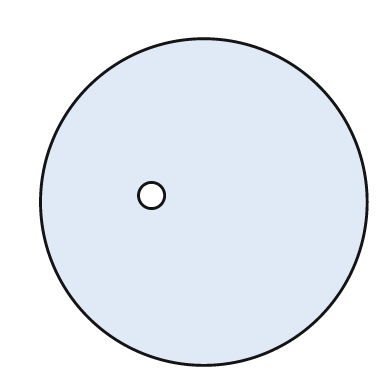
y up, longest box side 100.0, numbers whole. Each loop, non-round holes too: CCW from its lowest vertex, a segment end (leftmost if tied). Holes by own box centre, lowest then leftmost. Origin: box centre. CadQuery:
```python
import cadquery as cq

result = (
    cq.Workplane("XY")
    .moveTo(0.0, 0.0)
    .circle(50.0)
    .moveTo(-16.0, 2.0)
    .circle(4.0)
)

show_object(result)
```